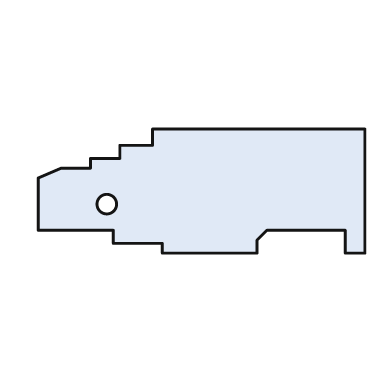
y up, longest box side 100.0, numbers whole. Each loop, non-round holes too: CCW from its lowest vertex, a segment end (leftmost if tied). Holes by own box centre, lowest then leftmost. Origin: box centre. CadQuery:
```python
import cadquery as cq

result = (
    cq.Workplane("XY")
    .moveTo(-12.0, -19.0)
    .lineTo(17.0, -19.0)
    .lineTo(17.0, -15.0)
    .lineTo(20.0, -12.0)
    .lineTo(44.0, -12.0)
    .lineTo(44.0, -19.0)
    .lineTo(50.0, -19.0)
    .lineTo(50.0, 19.0)
    .lineTo(-15.0, 19.0)
    .lineTo(-15.0, 14.0)
    .lineTo(-25.0, 14.0)
    .lineTo(-25.0, 10.0)
    .lineTo(-34.0, 10.0)
    .lineTo(-34.0, 7.0)
    .lineTo(-43.0, 7.0)
    .lineTo(-50.0, 4.0)
    .lineTo(-50.0, -12.0)
    .lineTo(-27.0, -12.0)
    .lineTo(-27.0, -16.0)
    .lineTo(-12.0, -16.0)
    .close()
    .moveTo(-29.0, -4.0)
    .circle(3.0)
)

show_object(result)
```